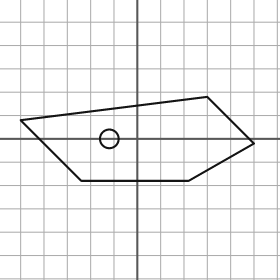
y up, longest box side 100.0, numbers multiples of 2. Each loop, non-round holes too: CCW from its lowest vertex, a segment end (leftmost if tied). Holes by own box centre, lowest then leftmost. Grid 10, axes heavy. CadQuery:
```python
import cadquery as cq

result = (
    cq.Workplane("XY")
    .moveTo(-24.0, -18.0)
    .lineTo(22.0, -18.0)
    .lineTo(50.0, -2.0)
    .lineTo(30.0, 18.0)
    .lineTo(-50.0, 8.0)
    .close()
    .moveTo(-12.0, 0.0)
    .circle(4.0)
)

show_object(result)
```